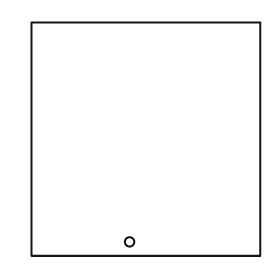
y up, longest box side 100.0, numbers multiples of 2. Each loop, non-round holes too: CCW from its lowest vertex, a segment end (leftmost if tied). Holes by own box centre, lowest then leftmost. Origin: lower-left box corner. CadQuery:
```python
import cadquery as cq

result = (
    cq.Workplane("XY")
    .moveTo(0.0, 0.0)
    .lineTo(98.0, 0.0)
    .lineTo(98.0, 100.0)
    .lineTo(0.0, 100.0)
    .close()
    .moveTo(42.0, 6.0)
    .circle(2.0)
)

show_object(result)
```